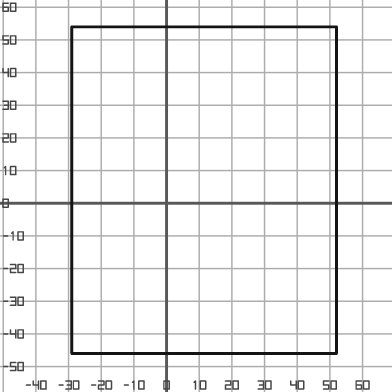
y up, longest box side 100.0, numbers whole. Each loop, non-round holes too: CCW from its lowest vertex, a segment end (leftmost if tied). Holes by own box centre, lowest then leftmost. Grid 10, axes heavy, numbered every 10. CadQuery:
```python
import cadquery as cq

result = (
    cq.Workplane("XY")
    .moveTo(-29.0, -46.0)
    .lineTo(52.0, -46.0)
    .lineTo(52.0, 54.0)
    .lineTo(-29.0, 54.0)
    .close()
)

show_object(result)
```